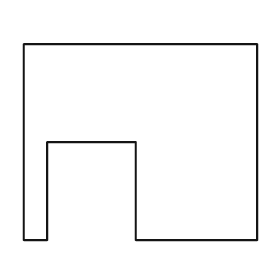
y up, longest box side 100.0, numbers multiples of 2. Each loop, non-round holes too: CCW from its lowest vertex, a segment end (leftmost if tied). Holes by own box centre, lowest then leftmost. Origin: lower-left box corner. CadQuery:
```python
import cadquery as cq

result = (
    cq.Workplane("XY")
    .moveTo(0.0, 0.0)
    .lineTo(10.0, 0.0)
    .lineTo(10.0, 42.0)
    .lineTo(48.0, 42.0)
    .lineTo(48.0, 0.0)
    .lineTo(100.0, 0.0)
    .lineTo(100.0, 84.0)
    .lineTo(0.0, 84.0)
    .close()
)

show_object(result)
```